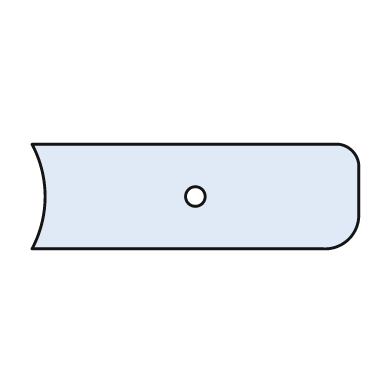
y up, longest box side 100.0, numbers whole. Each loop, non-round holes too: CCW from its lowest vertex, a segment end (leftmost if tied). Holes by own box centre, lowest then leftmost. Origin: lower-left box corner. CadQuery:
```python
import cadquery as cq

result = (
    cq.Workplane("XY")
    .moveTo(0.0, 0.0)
    .lineTo(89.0, 0.0)
    .threePointArc((97.0, 3.0), (100.0, 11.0))
    .lineTo(100.0, 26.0)
    .threePointArc((98.0, 30.0), (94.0, 32.0))
    .lineTo(0.0, 32.0)
    .threePointArc((4.0, 16.0), (0.0, 0.0))
    .close()
    .moveTo(50.0, 16.0)
    .circle(3.0)
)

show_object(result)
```